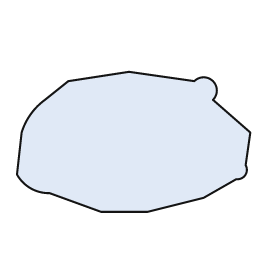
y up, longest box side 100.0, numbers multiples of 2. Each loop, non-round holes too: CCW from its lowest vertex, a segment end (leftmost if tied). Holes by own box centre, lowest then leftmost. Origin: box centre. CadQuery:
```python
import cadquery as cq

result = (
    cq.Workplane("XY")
    .moveTo(-14.0, -30.0)
    .lineTo(6.0, -30.0)
    .lineTo(30.0, -24.0)
    .lineTo(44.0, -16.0)
    .threePointArc((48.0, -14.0), (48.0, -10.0))
    .lineTo(50.0, 4.0)
    .lineTo(34.0, 18.0)
    .threePointArc((34.0, 26.0), (26.0, 26.0))
    .lineTo(-2.0, 30.0)
    .lineTo(-28.0, 26.0)
    .lineTo(-38.0, 18.0)
    .threePointArc((-44.0, 12.0), (-48.0, 4.0))
    .lineTo(-50.0, -14.0)
    .threePointArc((-44.0, -20.0), (-36.0, -22.0))
    .close()
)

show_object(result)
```